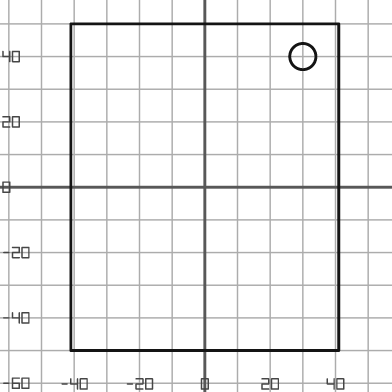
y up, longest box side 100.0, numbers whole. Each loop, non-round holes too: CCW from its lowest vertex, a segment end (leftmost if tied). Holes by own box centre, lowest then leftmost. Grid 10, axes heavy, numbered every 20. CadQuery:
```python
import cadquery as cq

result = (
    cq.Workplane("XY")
    .moveTo(-41.0, -50.0)
    .lineTo(41.0, -50.0)
    .lineTo(41.0, 50.0)
    .lineTo(-41.0, 50.0)
    .close()
    .moveTo(30.0, 40.0)
    .circle(4.0)
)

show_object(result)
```